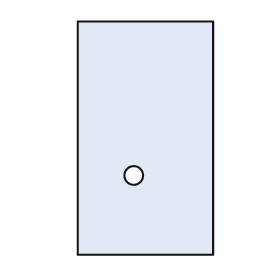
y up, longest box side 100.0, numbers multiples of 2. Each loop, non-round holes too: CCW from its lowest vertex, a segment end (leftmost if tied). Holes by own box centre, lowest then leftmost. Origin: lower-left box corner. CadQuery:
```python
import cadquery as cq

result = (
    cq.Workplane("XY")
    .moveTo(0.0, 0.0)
    .lineTo(58.0, 0.0)
    .lineTo(58.0, 100.0)
    .lineTo(0.0, 100.0)
    .close()
    .moveTo(24.0, 34.0)
    .circle(4.0)
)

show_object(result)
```